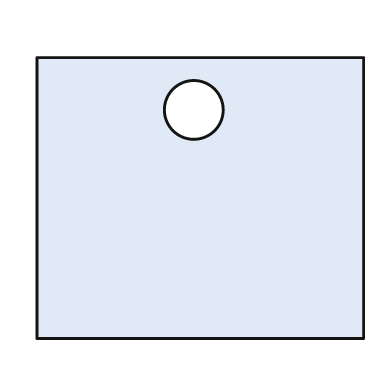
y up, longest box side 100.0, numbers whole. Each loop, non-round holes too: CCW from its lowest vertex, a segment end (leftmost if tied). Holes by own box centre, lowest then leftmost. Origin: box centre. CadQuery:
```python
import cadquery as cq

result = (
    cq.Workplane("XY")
    .moveTo(-50.0, -43.0)
    .lineTo(50.0, -43.0)
    .lineTo(50.0, 43.0)
    .lineTo(-50.0, 43.0)
    .close()
    .moveTo(-2.0, 27.0)
    .circle(9.0)
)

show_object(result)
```